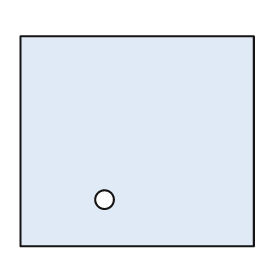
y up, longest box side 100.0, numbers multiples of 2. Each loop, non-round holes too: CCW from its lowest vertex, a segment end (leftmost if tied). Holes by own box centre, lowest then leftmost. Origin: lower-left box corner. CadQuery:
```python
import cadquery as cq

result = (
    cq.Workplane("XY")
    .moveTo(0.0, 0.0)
    .lineTo(100.0, 0.0)
    .lineTo(100.0, 90.0)
    .lineTo(0.0, 90.0)
    .close()
    .moveTo(36.0, 20.0)
    .circle(4.0)
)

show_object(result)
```